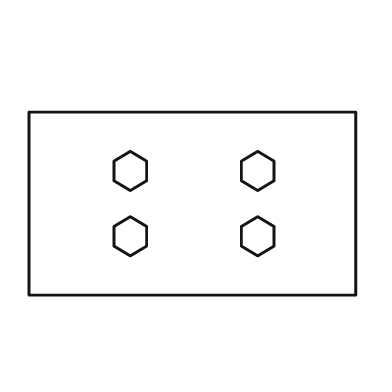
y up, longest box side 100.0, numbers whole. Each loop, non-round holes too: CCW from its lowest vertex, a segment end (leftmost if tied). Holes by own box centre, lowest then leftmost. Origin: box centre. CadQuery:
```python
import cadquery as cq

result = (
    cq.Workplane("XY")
    .moveTo(-50.0, -28.0)
    .lineTo(50.0, -28.0)
    .lineTo(50.0, 28.0)
    .lineTo(-50.0, 28.0)
    .close()
    .moveTo(-19.0, -16.0)
    .lineTo(-14.0, -13.0)
    .lineTo(-14.0, -7.0)
    .lineTo(-19.0, -4.0)
    .lineTo(-24.0, -7.0)
    .lineTo(-24.0, -13.0)
    .close()
    .moveTo(20.0, -16.0)
    .lineTo(25.0, -13.0)
    .lineTo(25.0, -7.0)
    .lineTo(20.0, -4.0)
    .lineTo(15.0, -7.0)
    .lineTo(15.0, -13.0)
    .close()
    .moveTo(-19.0, 4.0)
    .lineTo(-14.0, 7.0)
    .lineTo(-14.0, 13.0)
    .lineTo(-19.0, 16.0)
    .lineTo(-24.0, 13.0)
    .lineTo(-24.0, 7.0)
    .close()
    .moveTo(20.0, 4.0)
    .lineTo(25.0, 7.0)
    .lineTo(25.0, 13.0)
    .lineTo(20.0, 16.0)
    .lineTo(15.0, 13.0)
    .lineTo(15.0, 7.0)
    .close()
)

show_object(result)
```